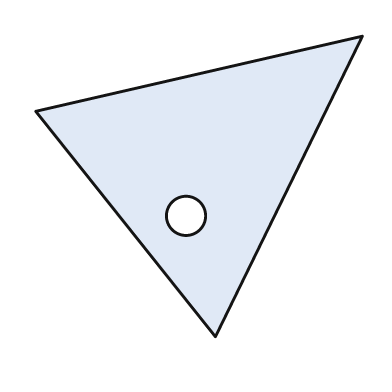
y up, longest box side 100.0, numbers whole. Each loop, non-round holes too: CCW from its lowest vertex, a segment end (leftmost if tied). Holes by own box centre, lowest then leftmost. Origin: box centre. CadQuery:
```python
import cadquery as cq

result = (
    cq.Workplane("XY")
    .moveTo(5.0, -46.0)
    .lineTo(50.0, 46.0)
    .lineTo(-50.0, 23.0)
    .close()
    .moveTo(-4.0, -9.0)
    .circle(6.0)
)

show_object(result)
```